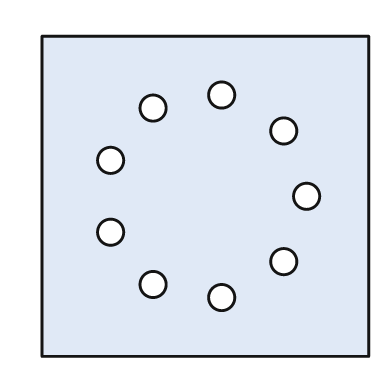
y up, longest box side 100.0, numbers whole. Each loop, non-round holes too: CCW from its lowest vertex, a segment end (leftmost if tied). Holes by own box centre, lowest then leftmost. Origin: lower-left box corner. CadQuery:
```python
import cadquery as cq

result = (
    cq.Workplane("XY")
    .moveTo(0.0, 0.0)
    .lineTo(100.0, 0.0)
    .lineTo(100.0, 98.0)
    .lineTo(0.0, 98.0)
    .close()
    .moveTo(55.0, 18.0)
    .circle(4.0)
    .moveTo(34.0, 22.0)
    .circle(4.0)
    .moveTo(74.0, 29.0)
    .circle(4.0)
    .moveTo(21.0, 38.0)
    .circle(4.0)
    .moveTo(81.0, 49.0)
    .circle(4.0)
    .moveTo(21.0, 60.0)
    .circle(4.0)
    .moveTo(74.0, 69.0)
    .circle(4.0)
    .moveTo(34.0, 76.0)
    .circle(4.0)
    .moveTo(55.0, 80.0)
    .circle(4.0)
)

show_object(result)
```